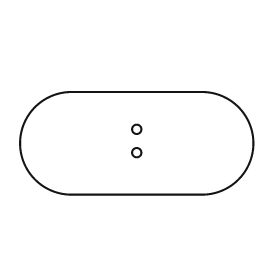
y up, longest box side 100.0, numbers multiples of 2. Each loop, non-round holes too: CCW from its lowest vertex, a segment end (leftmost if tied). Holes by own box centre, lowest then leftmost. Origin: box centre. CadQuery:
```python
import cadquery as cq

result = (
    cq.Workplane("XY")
    .moveTo(-28.0, -22.0)
    .lineTo(28.0, -22.0)
    .threePointArc((50.0, 0.0), (28.0, 22.0))
    .lineTo(-28.0, 22.0)
    .threePointArc((-50.0, 0.0), (-28.0, -22.0))
    .close()
    .moveTo(0.0, -4.0)
    .circle(2.0)
    .moveTo(0.0, 6.0)
    .circle(2.0)
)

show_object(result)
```